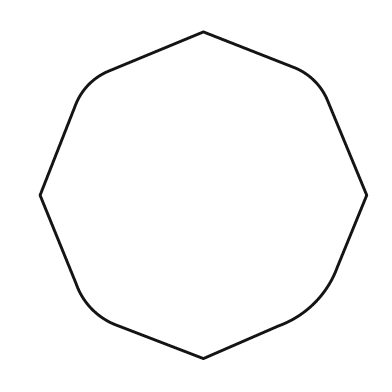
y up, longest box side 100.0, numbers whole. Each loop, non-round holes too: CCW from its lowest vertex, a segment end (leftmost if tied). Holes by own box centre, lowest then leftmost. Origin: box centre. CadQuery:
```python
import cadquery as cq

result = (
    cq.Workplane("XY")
    .moveTo(0.0, -50.0)
    .lineTo(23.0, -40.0)
    .threePointArc((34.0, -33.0), (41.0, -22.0))
    .lineTo(50.0, 0.0)
    .lineTo(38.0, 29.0)
    .threePointArc((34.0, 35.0), (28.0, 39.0))
    .lineTo(0.0, 50.0)
    .lineTo(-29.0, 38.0)
    .threePointArc((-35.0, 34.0), (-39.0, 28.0))
    .lineTo(-50.0, 0.0)
    .lineTo(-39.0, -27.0)
    .threePointArc((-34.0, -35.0), (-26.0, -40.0))
    .close()
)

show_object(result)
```